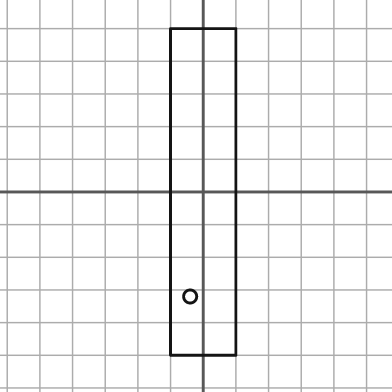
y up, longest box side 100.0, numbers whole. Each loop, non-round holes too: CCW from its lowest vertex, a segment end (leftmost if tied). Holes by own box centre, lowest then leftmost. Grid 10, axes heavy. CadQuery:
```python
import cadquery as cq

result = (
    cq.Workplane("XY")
    .moveTo(-10.0, -50.0)
    .lineTo(10.0, -50.0)
    .lineTo(10.0, 50.0)
    .lineTo(-10.0, 50.0)
    .close()
    .moveTo(-4.0, -32.0)
    .circle(2.0)
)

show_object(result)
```